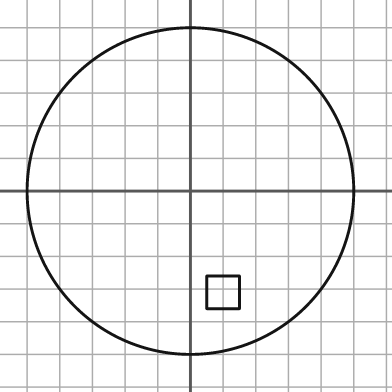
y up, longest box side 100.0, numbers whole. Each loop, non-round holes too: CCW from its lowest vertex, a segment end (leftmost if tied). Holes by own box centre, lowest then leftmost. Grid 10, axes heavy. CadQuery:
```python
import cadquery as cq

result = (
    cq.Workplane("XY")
    .moveTo(0.0, 0.0)
    .circle(50.0)
    .moveTo(5.0, -36.0)
    .lineTo(15.0, -36.0)
    .lineTo(15.0, -26.0)
    .lineTo(5.0, -26.0)
    .close()
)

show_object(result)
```